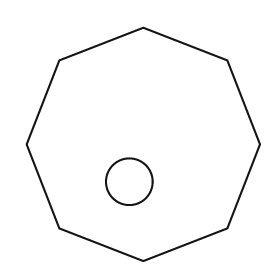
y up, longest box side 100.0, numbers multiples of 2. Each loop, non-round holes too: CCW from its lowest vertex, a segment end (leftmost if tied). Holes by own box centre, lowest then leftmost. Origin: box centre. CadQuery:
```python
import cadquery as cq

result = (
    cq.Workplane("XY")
    .moveTo(0.0, -50.0)
    .lineTo(36.0, -36.0)
    .lineTo(50.0, 0.0)
    .lineTo(36.0, 36.0)
    .lineTo(0.0, 50.0)
    .lineTo(-36.0, 36.0)
    .lineTo(-50.0, 0.0)
    .lineTo(-36.0, -36.0)
    .close()
    .moveTo(-6.0, -16.0)
    .circle(10.0)
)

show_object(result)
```